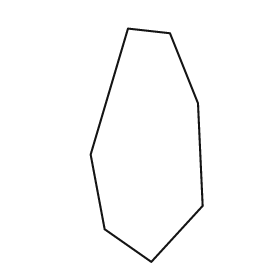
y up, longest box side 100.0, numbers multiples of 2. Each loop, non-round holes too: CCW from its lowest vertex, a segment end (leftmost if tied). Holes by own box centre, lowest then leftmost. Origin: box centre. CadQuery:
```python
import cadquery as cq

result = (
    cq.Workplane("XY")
    .moveTo(2.0, -50.0)
    .lineTo(24.0, -26.0)
    .lineTo(22.0, 18.0)
    .lineTo(10.0, 48.0)
    .lineTo(-8.0, 50.0)
    .lineTo(-24.0, -4.0)
    .lineTo(-18.0, -36.0)
    .close()
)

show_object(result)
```